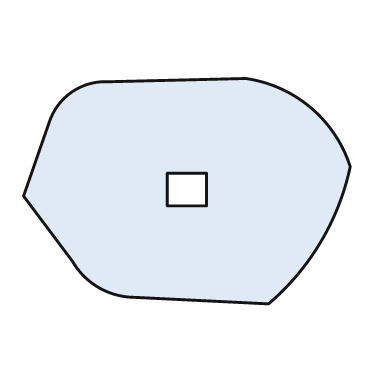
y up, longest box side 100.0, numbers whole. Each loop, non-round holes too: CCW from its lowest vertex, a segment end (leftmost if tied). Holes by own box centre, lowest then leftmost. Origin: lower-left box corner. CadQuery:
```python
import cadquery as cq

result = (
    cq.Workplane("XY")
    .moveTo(75.0, 0.0)
    .threePointArc((91.0, 19.0), (100.0, 42.0))
    .threePointArc((88.0, 60.0), (68.0, 69.0))
    .lineTo(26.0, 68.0)
    .threePointArc((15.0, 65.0), (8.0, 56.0))
    .lineTo(0.0, 33.0)
    .lineTo(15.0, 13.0)
    .threePointArc((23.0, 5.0), (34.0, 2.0))
    .close()
    .moveTo(44.0, 30.0)
    .lineTo(56.0, 30.0)
    .lineTo(56.0, 40.0)
    .lineTo(44.0, 40.0)
    .close()
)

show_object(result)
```